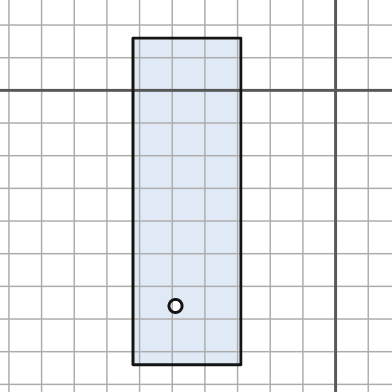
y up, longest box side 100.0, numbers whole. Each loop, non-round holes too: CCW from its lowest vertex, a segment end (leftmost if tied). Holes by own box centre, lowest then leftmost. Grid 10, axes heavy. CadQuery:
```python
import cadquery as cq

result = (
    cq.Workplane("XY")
    .moveTo(-62.0, -84.0)
    .lineTo(-29.0, -84.0)
    .lineTo(-29.0, 16.0)
    .lineTo(-62.0, 16.0)
    .close()
    .moveTo(-49.0, -66.0)
    .circle(2.0)
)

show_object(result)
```